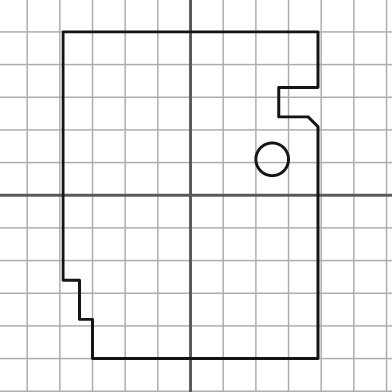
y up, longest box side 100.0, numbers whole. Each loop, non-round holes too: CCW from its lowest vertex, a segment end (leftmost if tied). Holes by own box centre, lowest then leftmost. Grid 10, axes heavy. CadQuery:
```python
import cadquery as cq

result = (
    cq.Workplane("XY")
    .moveTo(-30.0, -50.0)
    .lineTo(39.0, -50.0)
    .lineTo(39.0, 21.0)
    .lineTo(36.0, 24.0)
    .lineTo(27.0, 24.0)
    .lineTo(27.0, 33.0)
    .lineTo(39.0, 33.0)
    .lineTo(39.0, 50.0)
    .lineTo(-39.0, 50.0)
    .lineTo(-39.0, -26.0)
    .lineTo(-34.0, -26.0)
    .lineTo(-34.0, -38.0)
    .lineTo(-30.0, -38.0)
    .close()
    .moveTo(25.0, 11.0)
    .circle(5.0)
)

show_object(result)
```